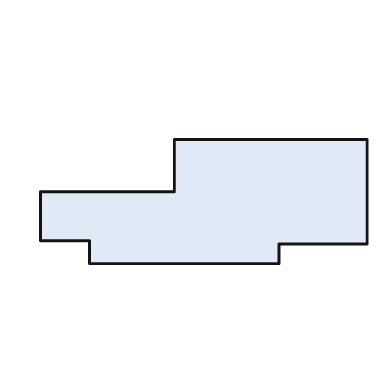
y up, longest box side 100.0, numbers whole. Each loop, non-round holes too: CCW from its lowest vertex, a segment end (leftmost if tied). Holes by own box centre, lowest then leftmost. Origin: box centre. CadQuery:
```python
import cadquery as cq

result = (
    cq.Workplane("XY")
    .moveTo(-35.0, -19.0)
    .lineTo(23.0, -19.0)
    .lineTo(23.0, -13.0)
    .lineTo(50.0, -13.0)
    .lineTo(50.0, 19.0)
    .lineTo(-9.0, 19.0)
    .lineTo(-9.0, 3.0)
    .lineTo(-50.0, 3.0)
    .lineTo(-50.0, -12.0)
    .lineTo(-35.0, -12.0)
    .close()
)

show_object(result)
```